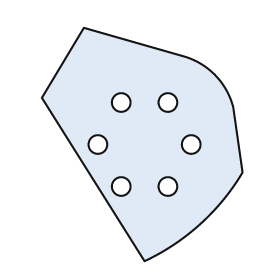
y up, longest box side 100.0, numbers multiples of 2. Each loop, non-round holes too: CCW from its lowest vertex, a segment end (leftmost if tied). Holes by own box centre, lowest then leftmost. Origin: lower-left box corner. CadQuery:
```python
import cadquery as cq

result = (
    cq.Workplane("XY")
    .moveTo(44.0, 0.0)
    .threePointArc((68.0, 16.0), (86.0, 38.0))
    .lineTo(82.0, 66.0)
    .threePointArc((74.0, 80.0), (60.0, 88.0))
    .lineTo(18.0, 100.0)
    .lineTo(0.0, 70.0)
    .close()
    .moveTo(34.0, 32.0)
    .circle(4.0)
    .moveTo(54.0, 32.0)
    .circle(4.0)
    .moveTo(24.0, 50.0)
    .circle(4.0)
    .moveTo(64.0, 50.0)
    .circle(4.0)
    .moveTo(34.0, 68.0)
    .circle(4.0)
    .moveTo(54.0, 68.0)
    .circle(4.0)
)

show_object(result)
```